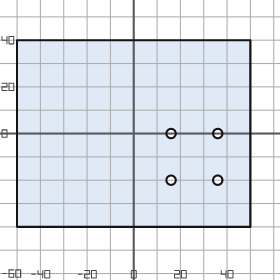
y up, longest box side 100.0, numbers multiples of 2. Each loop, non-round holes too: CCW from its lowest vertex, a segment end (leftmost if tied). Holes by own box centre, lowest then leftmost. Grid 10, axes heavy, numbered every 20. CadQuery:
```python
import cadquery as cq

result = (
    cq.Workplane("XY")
    .moveTo(-50.0, -40.0)
    .lineTo(50.0, -40.0)
    .lineTo(50.0, 40.0)
    .lineTo(-50.0, 40.0)
    .close()
    .moveTo(16.0, -20.0)
    .circle(2.0)
    .moveTo(36.0, -20.0)
    .circle(2.0)
    .moveTo(16.0, 0.0)
    .circle(2.0)
    .moveTo(36.0, 0.0)
    .circle(2.0)
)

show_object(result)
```